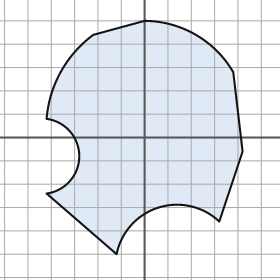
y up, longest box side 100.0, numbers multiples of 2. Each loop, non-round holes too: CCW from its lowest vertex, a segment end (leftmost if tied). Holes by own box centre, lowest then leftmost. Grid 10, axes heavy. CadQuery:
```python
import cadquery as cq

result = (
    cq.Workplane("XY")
    .moveTo(-12.0, -50.0)
    .threePointArc((6.0, -30.0), (32.0, -36.0))
    .lineTo(42.0, -6.0)
    .lineTo(38.0, 28.0)
    .threePointArc((22.0, 44.0), (0.0, 50.0))
    .lineTo(-22.0, 44.0)
    .threePointArc((-36.0, 28.0), (-42.0, 8.0))
    .threePointArc((-28.0, -8.0), (-42.0, -24.0))
    .close()
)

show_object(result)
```